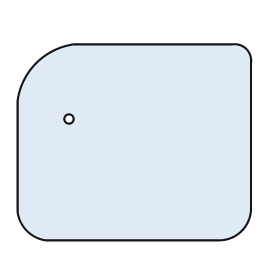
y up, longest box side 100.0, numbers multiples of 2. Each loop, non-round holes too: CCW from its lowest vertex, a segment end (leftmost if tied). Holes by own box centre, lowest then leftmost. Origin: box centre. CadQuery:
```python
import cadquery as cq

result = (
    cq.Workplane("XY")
    .moveTo(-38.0, -42.0)
    .lineTo(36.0, -42.0)
    .threePointArc((46.0, -38.0), (50.0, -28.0))
    .lineTo(50.0, 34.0)
    .threePointArc((48.0, 40.0), (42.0, 42.0))
    .lineTo(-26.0, 42.0)
    .threePointArc((-42.0, 34.0), (-50.0, 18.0))
    .lineTo(-50.0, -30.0)
    .threePointArc((-46.0, -38.0), (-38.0, -42.0))
    .close()
    .moveTo(-28.0, 10.0)
    .circle(2.0)
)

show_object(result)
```